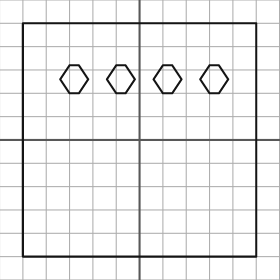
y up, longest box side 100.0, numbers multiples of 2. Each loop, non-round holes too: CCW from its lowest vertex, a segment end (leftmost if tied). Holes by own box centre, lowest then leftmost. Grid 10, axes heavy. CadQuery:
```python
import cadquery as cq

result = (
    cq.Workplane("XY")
    .moveTo(-50.0, -50.0)
    .lineTo(50.0, -50.0)
    .lineTo(50.0, 50.0)
    .lineTo(-50.0, 50.0)
    .close()
    .moveTo(-30.0, 20.0)
    .lineTo(-26.0, 20.0)
    .lineTo(-22.0, 26.0)
    .lineTo(-26.0, 32.0)
    .lineTo(-30.0, 32.0)
    .lineTo(-34.0, 26.0)
    .close()
    .moveTo(-10.0, 20.0)
    .lineTo(-6.0, 20.0)
    .lineTo(-2.0, 26.0)
    .lineTo(-6.0, 32.0)
    .lineTo(-10.0, 32.0)
    .lineTo(-14.0, 26.0)
    .close()
    .moveTo(10.0, 20.0)
    .lineTo(14.0, 20.0)
    .lineTo(18.0, 26.0)
    .lineTo(14.0, 32.0)
    .lineTo(10.0, 32.0)
    .lineTo(6.0, 26.0)
    .close()
    .moveTo(30.0, 20.0)
    .lineTo(34.0, 20.0)
    .lineTo(38.0, 26.0)
    .lineTo(34.0, 32.0)
    .lineTo(30.0, 32.0)
    .lineTo(26.0, 26.0)
    .close()
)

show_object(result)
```